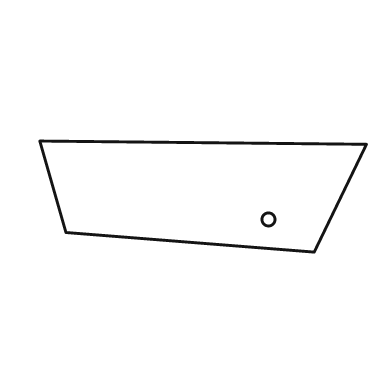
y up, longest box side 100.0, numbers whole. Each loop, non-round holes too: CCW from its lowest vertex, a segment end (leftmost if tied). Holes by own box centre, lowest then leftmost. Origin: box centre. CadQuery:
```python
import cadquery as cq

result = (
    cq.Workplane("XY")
    .moveTo(34.0, -17.0)
    .lineTo(50.0, 16.0)
    .lineTo(-50.0, 17.0)
    .lineTo(-42.0, -11.0)
    .close()
    .moveTo(20.0, -7.0)
    .circle(2.0)
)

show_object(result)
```